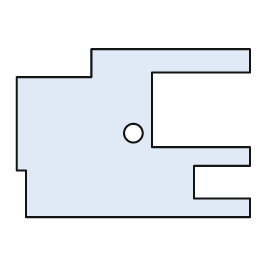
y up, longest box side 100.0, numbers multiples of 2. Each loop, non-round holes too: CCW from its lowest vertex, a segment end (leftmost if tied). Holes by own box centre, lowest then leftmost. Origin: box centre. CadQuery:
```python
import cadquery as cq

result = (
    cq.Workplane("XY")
    .moveTo(-46.0, -36.0)
    .lineTo(50.0, -36.0)
    .lineTo(50.0, -28.0)
    .lineTo(26.0, -28.0)
    .lineTo(26.0, -14.0)
    .lineTo(50.0, -14.0)
    .lineTo(50.0, -6.0)
    .lineTo(8.0, -6.0)
    .lineTo(8.0, 26.0)
    .lineTo(50.0, 26.0)
    .lineTo(50.0, 36.0)
    .lineTo(-18.0, 36.0)
    .lineTo(-18.0, 24.0)
    .lineTo(-50.0, 24.0)
    .lineTo(-50.0, -16.0)
    .lineTo(-46.0, -16.0)
    .close()
    .moveTo(0.0, 0.0)
    .circle(4.0)
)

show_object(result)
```